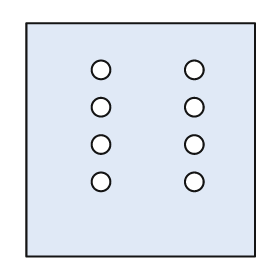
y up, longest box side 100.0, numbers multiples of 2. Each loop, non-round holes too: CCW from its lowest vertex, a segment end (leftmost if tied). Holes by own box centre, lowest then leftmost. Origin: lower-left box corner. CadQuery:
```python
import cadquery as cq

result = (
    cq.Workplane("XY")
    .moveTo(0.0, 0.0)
    .lineTo(98.0, 0.0)
    .lineTo(98.0, 100.0)
    .lineTo(0.0, 100.0)
    .close()
    .moveTo(32.0, 32.0)
    .circle(4.0)
    .moveTo(72.0, 32.0)
    .circle(4.0)
    .moveTo(32.0, 48.0)
    .circle(4.0)
    .moveTo(72.0, 48.0)
    .circle(4.0)
    .moveTo(32.0, 64.0)
    .circle(4.0)
    .moveTo(72.0, 64.0)
    .circle(4.0)
    .moveTo(32.0, 80.0)
    .circle(4.0)
    .moveTo(72.0, 80.0)
    .circle(4.0)
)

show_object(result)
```